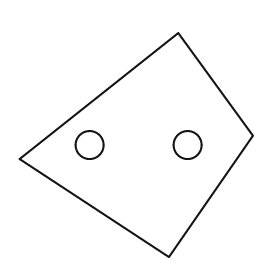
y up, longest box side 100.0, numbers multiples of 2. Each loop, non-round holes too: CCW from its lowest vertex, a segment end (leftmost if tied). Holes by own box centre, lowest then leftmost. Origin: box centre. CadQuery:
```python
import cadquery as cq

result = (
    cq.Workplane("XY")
    .moveTo(14.0, -48.0)
    .lineTo(50.0, 4.0)
    .lineTo(18.0, 48.0)
    .lineTo(-50.0, -6.0)
    .close()
    .moveTo(-20.0, 0.0)
    .circle(6.0)
    .moveTo(22.0, 0.0)
    .circle(6.0)
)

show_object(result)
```